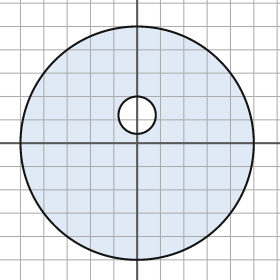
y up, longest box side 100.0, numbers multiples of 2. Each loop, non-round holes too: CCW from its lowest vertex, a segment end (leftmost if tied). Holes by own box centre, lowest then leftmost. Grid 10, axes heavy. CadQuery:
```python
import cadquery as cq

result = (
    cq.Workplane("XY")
    .moveTo(0.0, 0.0)
    .circle(50.0)
    .moveTo(0.0, 12.0)
    .circle(8.0)
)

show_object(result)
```